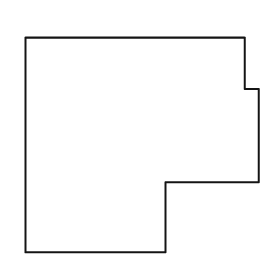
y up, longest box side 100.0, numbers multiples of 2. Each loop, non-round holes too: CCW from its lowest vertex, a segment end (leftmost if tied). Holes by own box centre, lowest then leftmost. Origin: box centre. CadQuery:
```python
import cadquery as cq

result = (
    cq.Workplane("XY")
    .moveTo(-50.0, -46.0)
    .lineTo(10.0, -46.0)
    .lineTo(10.0, -16.0)
    .lineTo(50.0, -16.0)
    .lineTo(50.0, 24.0)
    .lineTo(44.0, 24.0)
    .lineTo(44.0, 46.0)
    .lineTo(-50.0, 46.0)
    .close()
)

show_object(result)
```